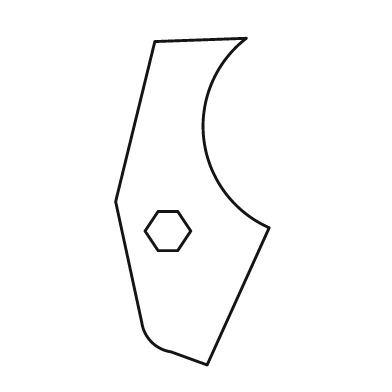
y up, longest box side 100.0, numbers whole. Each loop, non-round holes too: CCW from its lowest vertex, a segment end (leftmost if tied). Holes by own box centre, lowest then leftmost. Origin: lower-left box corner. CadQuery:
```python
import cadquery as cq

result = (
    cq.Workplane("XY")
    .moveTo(28.0, 0.0)
    .lineTo(47.0, 42.0)
    .threePointArc((27.0, 69.0), (40.0, 100.0))
    .lineTo(12.0, 99.0)
    .lineTo(0.0, 50.0)
    .lineTo(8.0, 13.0)
    .threePointArc((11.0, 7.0), (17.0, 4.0))
    .close()
    .moveTo(13.0, 35.0)
    .lineTo(19.0, 35.0)
    .lineTo(23.0, 41.0)
    .lineTo(19.0, 47.0)
    .lineTo(13.0, 47.0)
    .lineTo(9.0, 41.0)
    .close()
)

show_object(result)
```